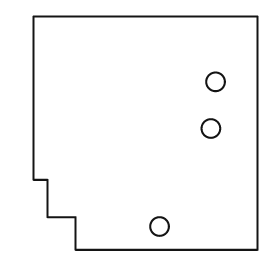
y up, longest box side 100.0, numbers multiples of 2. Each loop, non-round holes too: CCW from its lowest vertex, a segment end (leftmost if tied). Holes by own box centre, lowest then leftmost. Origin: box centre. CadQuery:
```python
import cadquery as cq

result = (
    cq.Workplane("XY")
    .moveTo(-30.0, -50.0)
    .lineTo(48.0, -50.0)
    .lineTo(48.0, 50.0)
    .lineTo(-48.0, 50.0)
    .lineTo(-48.0, -20.0)
    .lineTo(-42.0, -20.0)
    .lineTo(-42.0, -36.0)
    .lineTo(-30.0, -36.0)
    .close()
    .moveTo(6.0, -40.0)
    .circle(4.0)
    .moveTo(28.0, 2.0)
    .circle(4.0)
    .moveTo(30.0, 22.0)
    .circle(4.0)
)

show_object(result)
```